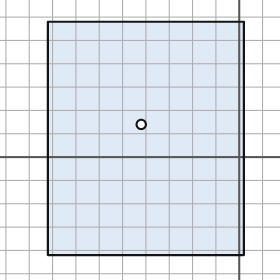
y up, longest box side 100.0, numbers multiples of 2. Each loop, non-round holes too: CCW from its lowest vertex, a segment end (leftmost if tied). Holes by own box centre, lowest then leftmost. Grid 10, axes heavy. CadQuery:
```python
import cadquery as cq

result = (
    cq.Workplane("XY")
    .moveTo(-82.0, -42.0)
    .lineTo(2.0, -42.0)
    .lineTo(2.0, 58.0)
    .lineTo(-82.0, 58.0)
    .close()
    .moveTo(-42.0, 14.0)
    .circle(2.0)
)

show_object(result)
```